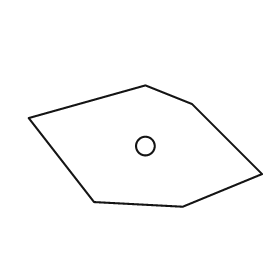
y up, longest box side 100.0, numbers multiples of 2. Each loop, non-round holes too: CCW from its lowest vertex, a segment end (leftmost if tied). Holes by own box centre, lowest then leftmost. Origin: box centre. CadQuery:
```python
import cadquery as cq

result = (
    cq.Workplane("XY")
    .moveTo(16.0, -26.0)
    .lineTo(50.0, -12.0)
    .lineTo(20.0, 18.0)
    .lineTo(0.0, 26.0)
    .lineTo(-50.0, 12.0)
    .lineTo(-22.0, -24.0)
    .close()
    .moveTo(0.0, 0.0)
    .circle(4.0)
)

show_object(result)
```